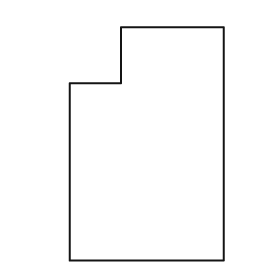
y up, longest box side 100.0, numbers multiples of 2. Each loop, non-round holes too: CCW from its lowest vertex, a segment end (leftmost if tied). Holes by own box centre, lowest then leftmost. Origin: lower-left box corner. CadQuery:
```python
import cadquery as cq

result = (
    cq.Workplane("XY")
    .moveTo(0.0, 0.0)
    .lineTo(66.0, 0.0)
    .lineTo(66.0, 100.0)
    .lineTo(22.0, 100.0)
    .lineTo(22.0, 76.0)
    .lineTo(0.0, 76.0)
    .close()
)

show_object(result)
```